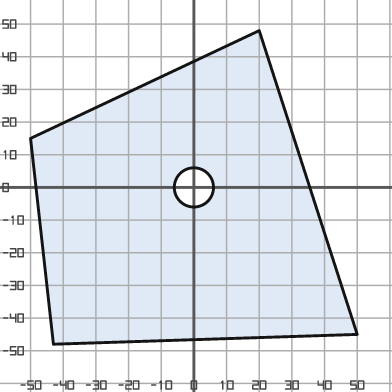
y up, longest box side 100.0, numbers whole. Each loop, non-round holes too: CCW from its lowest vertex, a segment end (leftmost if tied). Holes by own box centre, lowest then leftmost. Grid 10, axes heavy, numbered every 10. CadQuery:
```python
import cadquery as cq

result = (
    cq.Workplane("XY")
    .moveTo(-43.0, -48.0)
    .lineTo(50.0, -45.0)
    .lineTo(20.0, 48.0)
    .lineTo(-50.0, 15.0)
    .close()
    .moveTo(0.0, 0.0)
    .circle(6.0)
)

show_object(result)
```